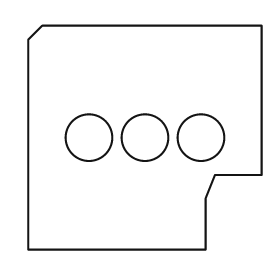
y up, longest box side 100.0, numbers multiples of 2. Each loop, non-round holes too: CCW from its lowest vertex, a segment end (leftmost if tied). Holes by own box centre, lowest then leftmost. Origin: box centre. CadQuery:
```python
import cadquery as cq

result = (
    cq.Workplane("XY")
    .moveTo(-50.0, -48.0)
    .lineTo(26.0, -48.0)
    .lineTo(26.0, -26.0)
    .lineTo(30.0, -16.0)
    .lineTo(50.0, -16.0)
    .lineTo(50.0, 48.0)
    .lineTo(-44.0, 48.0)
    .lineTo(-50.0, 42.0)
    .close()
    .moveTo(-24.0, 0.0)
    .circle(10.0)
    .moveTo(0.0, 0.0)
    .circle(10.0)
    .moveTo(24.0, 0.0)
    .circle(10.0)
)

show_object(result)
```